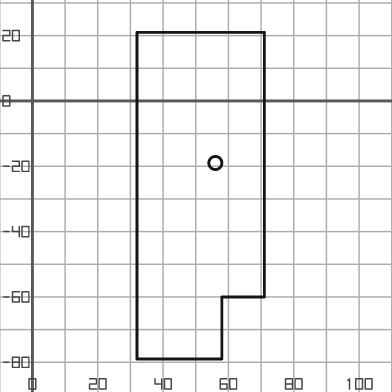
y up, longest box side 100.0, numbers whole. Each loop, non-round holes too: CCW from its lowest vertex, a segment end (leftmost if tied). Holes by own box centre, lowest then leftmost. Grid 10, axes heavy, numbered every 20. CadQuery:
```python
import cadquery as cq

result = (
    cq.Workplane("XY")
    .moveTo(32.0, -79.0)
    .lineTo(58.0, -79.0)
    .lineTo(58.0, -60.0)
    .lineTo(71.0, -60.0)
    .lineTo(71.0, 21.0)
    .lineTo(32.0, 21.0)
    .close()
    .moveTo(56.0, -19.0)
    .circle(2.0)
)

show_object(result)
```